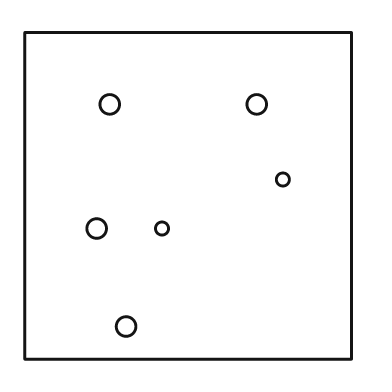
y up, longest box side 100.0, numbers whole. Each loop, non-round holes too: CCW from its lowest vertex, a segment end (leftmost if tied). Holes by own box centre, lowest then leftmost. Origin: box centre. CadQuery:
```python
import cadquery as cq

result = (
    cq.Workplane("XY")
    .moveTo(-50.0, -50.0)
    .lineTo(50.0, -50.0)
    .lineTo(50.0, 50.0)
    .lineTo(-50.0, 50.0)
    .close()
    .moveTo(-19.0, -40.0)
    .circle(3.0)
    .moveTo(-28.0, -10.0)
    .circle(3.0)
    .moveTo(-8.0, -10.0)
    .circle(2.0)
    .moveTo(29.0, 5.0)
    .circle(2.0)
    .moveTo(-24.0, 28.0)
    .circle(3.0)
    .moveTo(21.0, 28.0)
    .circle(3.0)
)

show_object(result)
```